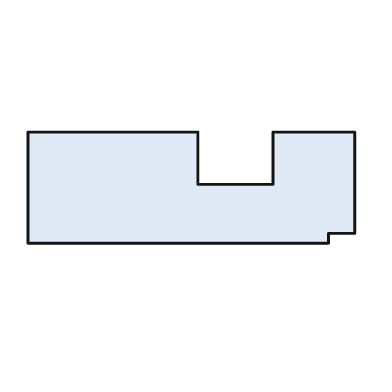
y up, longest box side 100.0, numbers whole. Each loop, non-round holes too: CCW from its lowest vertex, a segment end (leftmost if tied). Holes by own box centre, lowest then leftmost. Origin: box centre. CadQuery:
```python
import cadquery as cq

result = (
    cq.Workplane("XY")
    .moveTo(-50.0, -17.0)
    .lineTo(42.0, -17.0)
    .lineTo(42.0, -14.0)
    .lineTo(50.0, -14.0)
    .lineTo(50.0, 17.0)
    .lineTo(25.0, 17.0)
    .lineTo(25.0, 1.0)
    .lineTo(2.0, 1.0)
    .lineTo(2.0, 17.0)
    .lineTo(-50.0, 17.0)
    .close()
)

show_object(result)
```